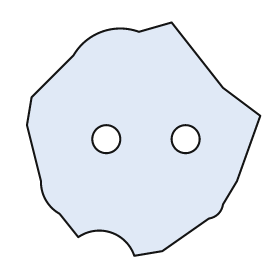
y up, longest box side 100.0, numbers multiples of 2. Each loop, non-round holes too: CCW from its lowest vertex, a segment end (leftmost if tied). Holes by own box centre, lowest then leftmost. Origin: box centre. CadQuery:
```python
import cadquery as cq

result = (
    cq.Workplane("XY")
    .moveTo(-4.0, -50.0)
    .lineTo(8.0, -48.0)
    .lineTo(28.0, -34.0)
    .threePointArc((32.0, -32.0), (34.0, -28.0))
    .lineTo(40.0, -18.0)
    .lineTo(50.0, 10.0)
    .lineTo(34.0, 22.0)
    .lineTo(12.0, 50.0)
    .lineTo(-2.0, 46.0)
    .threePointArc((-18.0, 46.0), (-30.0, 36.0))
    .lineTo(-48.0, 18.0)
    .lineTo(-50.0, 6.0)
    .lineTo(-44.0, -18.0)
    .threePointArc((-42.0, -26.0), (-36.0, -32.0))
    .lineTo(-28.0, -42.0)
    .threePointArc((-14.0, -40.0), (-4.0, -50.0))
    .close()
    .moveTo(-16.0, 0.0)
    .circle(6.0)
    .moveTo(18.0, 0.0)
    .circle(6.0)
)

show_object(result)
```